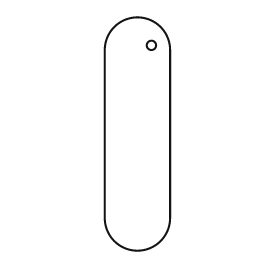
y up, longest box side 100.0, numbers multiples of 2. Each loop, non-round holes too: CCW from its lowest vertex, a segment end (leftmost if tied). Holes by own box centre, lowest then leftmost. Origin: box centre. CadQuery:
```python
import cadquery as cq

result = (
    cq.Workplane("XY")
    .moveTo(-14.0, -36.0)
    .threePointArc((0.0, -50.0), (14.0, -36.0))
    .lineTo(14.0, 36.0)
    .threePointArc((0.0, 50.0), (-14.0, 36.0))
    .close()
    .moveTo(6.0, 38.0)
    .circle(2.0)
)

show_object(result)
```